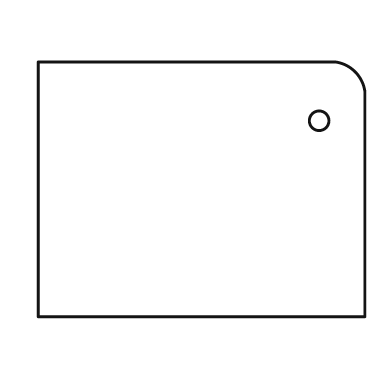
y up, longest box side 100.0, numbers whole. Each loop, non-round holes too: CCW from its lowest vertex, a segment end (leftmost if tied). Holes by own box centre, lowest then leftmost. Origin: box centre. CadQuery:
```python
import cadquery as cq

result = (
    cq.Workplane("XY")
    .moveTo(-50.0, -39.0)
    .lineTo(50.0, -39.0)
    .lineTo(50.0, 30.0)
    .threePointArc((47.0, 36.0), (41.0, 39.0))
    .lineTo(-50.0, 39.0)
    .close()
    .moveTo(36.0, 21.0)
    .circle(3.0)
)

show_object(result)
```